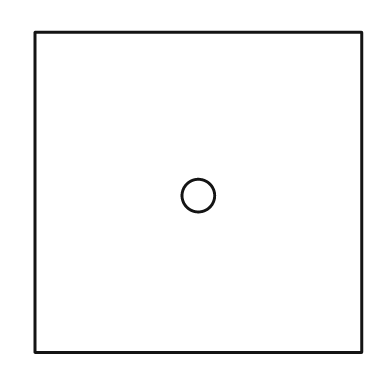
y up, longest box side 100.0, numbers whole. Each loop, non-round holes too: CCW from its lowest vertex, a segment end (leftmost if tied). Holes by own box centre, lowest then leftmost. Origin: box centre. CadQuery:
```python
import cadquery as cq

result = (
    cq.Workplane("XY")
    .moveTo(-50.0, -49.0)
    .lineTo(50.0, -49.0)
    .lineTo(50.0, 49.0)
    .lineTo(-50.0, 49.0)
    .close()
    .moveTo(0.0, -1.0)
    .circle(5.0)
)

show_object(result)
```